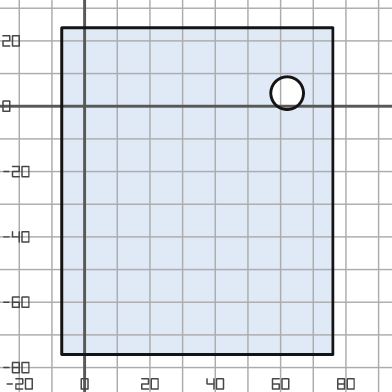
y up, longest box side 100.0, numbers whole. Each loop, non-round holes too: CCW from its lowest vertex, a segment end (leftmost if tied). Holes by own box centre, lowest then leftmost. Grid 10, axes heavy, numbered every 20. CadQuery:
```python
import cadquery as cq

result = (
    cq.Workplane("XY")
    .moveTo(-7.0, -76.0)
    .lineTo(76.0, -76.0)
    .lineTo(76.0, 24.0)
    .lineTo(-7.0, 24.0)
    .close()
    .moveTo(62.0, 4.0)
    .circle(5.0)
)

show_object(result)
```